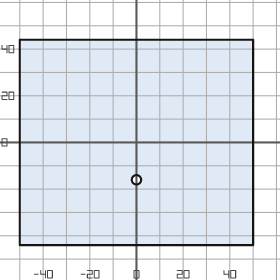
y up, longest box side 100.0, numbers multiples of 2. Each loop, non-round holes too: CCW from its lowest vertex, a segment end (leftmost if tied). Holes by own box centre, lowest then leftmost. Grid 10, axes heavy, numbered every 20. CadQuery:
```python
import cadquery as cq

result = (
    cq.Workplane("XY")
    .moveTo(-50.0, -44.0)
    .lineTo(50.0, -44.0)
    .lineTo(50.0, 44.0)
    .lineTo(-50.0, 44.0)
    .close()
    .moveTo(0.0, -16.0)
    .circle(2.0)
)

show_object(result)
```